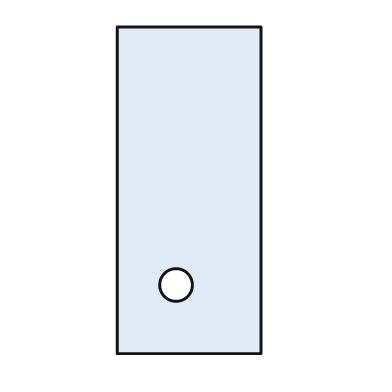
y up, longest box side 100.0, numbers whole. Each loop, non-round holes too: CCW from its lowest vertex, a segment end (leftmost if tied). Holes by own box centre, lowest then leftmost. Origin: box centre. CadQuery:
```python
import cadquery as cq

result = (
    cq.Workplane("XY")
    .moveTo(-22.0, -50.0)
    .lineTo(22.0, -50.0)
    .lineTo(22.0, 50.0)
    .lineTo(-22.0, 50.0)
    .close()
    .moveTo(-4.0, -29.0)
    .circle(5.0)
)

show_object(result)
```